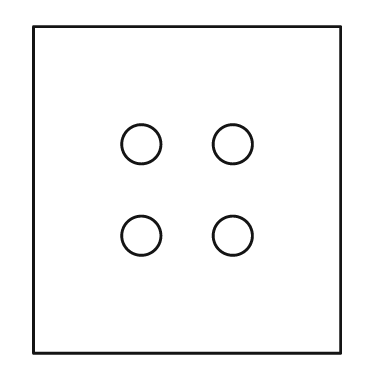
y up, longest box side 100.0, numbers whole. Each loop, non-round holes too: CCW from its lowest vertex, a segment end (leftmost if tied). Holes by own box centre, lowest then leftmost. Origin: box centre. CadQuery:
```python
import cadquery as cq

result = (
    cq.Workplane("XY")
    .moveTo(-47.0, -50.0)
    .lineTo(47.0, -50.0)
    .lineTo(47.0, 50.0)
    .lineTo(-47.0, 50.0)
    .close()
    .moveTo(-14.0, -14.0)
    .circle(6.0)
    .moveTo(14.0, -14.0)
    .circle(6.0)
    .moveTo(-14.0, 14.0)
    .circle(6.0)
    .moveTo(14.0, 14.0)
    .circle(6.0)
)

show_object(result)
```